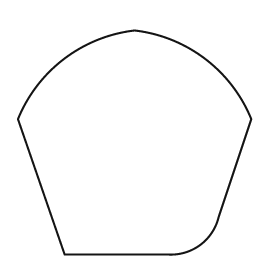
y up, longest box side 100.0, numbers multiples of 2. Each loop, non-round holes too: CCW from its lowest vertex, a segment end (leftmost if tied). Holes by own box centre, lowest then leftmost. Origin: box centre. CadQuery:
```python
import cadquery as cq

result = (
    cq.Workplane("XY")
    .moveTo(-30.0, -48.0)
    .lineTo(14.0, -48.0)
    .threePointArc((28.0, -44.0), (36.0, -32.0))
    .lineTo(50.0, 10.0)
    .threePointArc((30.0, 36.0), (0.0, 48.0))
    .threePointArc((-30.0, 36.0), (-50.0, 10.0))
    .close()
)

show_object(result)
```